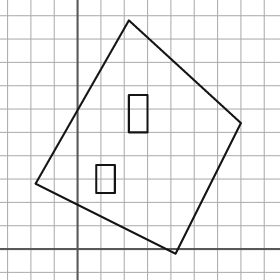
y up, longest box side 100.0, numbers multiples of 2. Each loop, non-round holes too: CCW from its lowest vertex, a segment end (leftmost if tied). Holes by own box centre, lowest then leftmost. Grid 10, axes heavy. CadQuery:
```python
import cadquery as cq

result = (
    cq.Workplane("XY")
    .moveTo(42.0, -2.0)
    .lineTo(70.0, 54.0)
    .lineTo(22.0, 98.0)
    .lineTo(-18.0, 28.0)
    .close()
    .moveTo(8.0, 24.0)
    .lineTo(16.0, 24.0)
    .lineTo(16.0, 36.0)
    .lineTo(8.0, 36.0)
    .close()
    .moveTo(22.0, 50.0)
    .lineTo(30.0, 50.0)
    .lineTo(30.0, 66.0)
    .lineTo(22.0, 66.0)
    .close()
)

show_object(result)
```